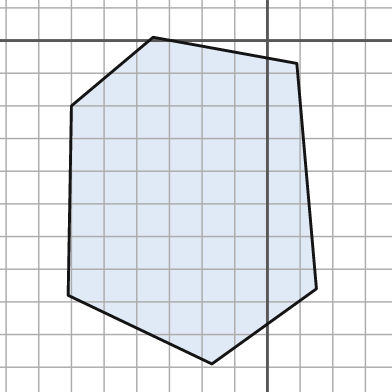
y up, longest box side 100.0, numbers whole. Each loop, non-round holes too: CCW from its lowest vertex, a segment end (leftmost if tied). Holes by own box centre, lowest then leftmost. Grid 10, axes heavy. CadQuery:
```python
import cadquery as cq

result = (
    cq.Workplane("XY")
    .moveTo(-17.0, -99.0)
    .lineTo(15.0, -76.0)
    .lineTo(9.0, -7.0)
    .lineTo(-35.0, 1.0)
    .lineTo(-60.0, -20.0)
    .lineTo(-61.0, -78.0)
    .close()
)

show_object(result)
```